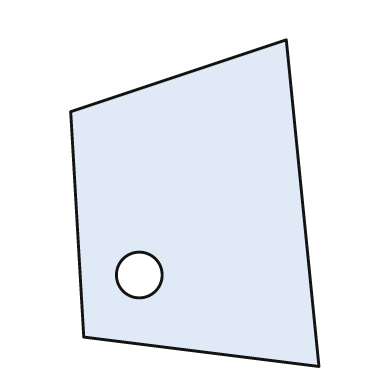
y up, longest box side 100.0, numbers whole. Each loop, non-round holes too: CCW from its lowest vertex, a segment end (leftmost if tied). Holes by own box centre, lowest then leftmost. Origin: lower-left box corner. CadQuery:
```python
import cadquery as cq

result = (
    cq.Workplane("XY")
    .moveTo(76.0, 0.0)
    .lineTo(66.0, 100.0)
    .lineTo(0.0, 78.0)
    .lineTo(4.0, 9.0)
    .close()
    .moveTo(21.0, 28.0)
    .circle(7.0)
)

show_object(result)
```